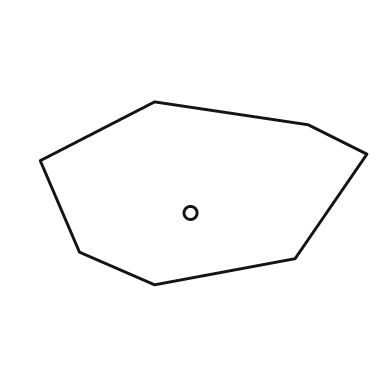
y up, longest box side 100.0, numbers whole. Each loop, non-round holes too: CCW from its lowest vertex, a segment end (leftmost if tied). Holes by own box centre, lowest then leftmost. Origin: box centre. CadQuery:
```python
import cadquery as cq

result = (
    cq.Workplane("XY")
    .moveTo(-15.0, -28.0)
    .lineTo(28.0, -20.0)
    .lineTo(50.0, 12.0)
    .lineTo(32.0, 21.0)
    .lineTo(-15.0, 28.0)
    .lineTo(-50.0, 10.0)
    .lineTo(-38.0, -18.0)
    .close()
    .moveTo(-4.0, -6.0)
    .circle(2.0)
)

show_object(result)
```